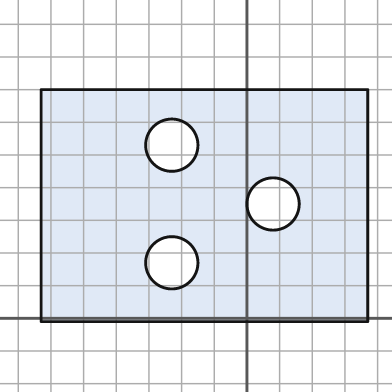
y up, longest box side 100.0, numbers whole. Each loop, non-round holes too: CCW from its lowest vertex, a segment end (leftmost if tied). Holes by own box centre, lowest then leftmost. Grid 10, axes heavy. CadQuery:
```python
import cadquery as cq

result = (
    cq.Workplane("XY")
    .moveTo(-63.0, -1.0)
    .lineTo(37.0, -1.0)
    .lineTo(37.0, 70.0)
    .lineTo(-63.0, 70.0)
    .close()
    .moveTo(-23.0, 17.0)
    .circle(8.0)
    .moveTo(8.0, 35.0)
    .circle(8.0)
    .moveTo(-23.0, 53.0)
    .circle(8.0)
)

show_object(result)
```